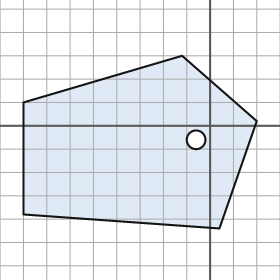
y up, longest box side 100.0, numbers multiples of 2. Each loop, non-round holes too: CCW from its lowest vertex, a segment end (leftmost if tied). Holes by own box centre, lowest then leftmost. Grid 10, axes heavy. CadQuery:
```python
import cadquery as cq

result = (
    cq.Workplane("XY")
    .moveTo(4.0, -44.0)
    .lineTo(20.0, 2.0)
    .lineTo(-12.0, 30.0)
    .lineTo(-80.0, 10.0)
    .lineTo(-80.0, -38.0)
    .close()
    .moveTo(-6.0, -6.0)
    .circle(4.0)
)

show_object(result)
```